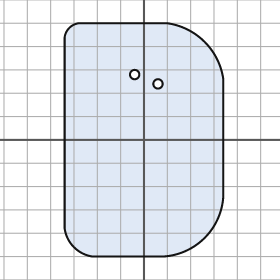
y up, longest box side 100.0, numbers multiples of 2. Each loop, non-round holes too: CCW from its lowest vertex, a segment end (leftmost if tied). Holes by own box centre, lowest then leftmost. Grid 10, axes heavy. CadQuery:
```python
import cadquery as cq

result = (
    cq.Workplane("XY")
    .moveTo(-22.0, -50.0)
    .lineTo(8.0, -50.0)
    .threePointArc((26.0, -42.0), (34.0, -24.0))
    .lineTo(34.0, 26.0)
    .threePointArc((26.0, 42.0), (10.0, 50.0))
    .lineTo(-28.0, 50.0)
    .threePointArc((-32.0, 48.0), (-34.0, 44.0))
    .lineTo(-34.0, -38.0)
    .threePointArc((-30.0, -46.0), (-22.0, -50.0))
    .close()
    .moveTo(6.0, 24.0)
    .circle(2.0)
    .moveTo(-4.0, 28.0)
    .circle(2.0)
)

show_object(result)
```